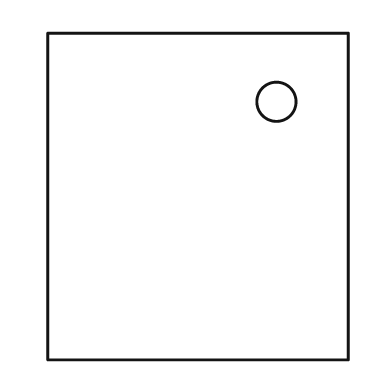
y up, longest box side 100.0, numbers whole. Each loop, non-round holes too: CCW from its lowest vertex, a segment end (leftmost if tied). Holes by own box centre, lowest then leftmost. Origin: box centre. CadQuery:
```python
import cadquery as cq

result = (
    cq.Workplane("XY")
    .moveTo(-46.0, -50.0)
    .lineTo(46.0, -50.0)
    .lineTo(46.0, 50.0)
    .lineTo(-46.0, 50.0)
    .close()
    .moveTo(24.0, 29.0)
    .circle(6.0)
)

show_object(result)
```